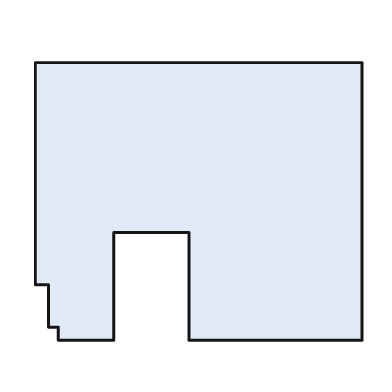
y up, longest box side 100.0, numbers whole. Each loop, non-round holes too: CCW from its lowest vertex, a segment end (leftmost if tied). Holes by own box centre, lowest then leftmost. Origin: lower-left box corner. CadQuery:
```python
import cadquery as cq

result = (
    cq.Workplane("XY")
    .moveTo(7.0, 0.0)
    .lineTo(24.0, 0.0)
    .lineTo(24.0, 33.0)
    .lineTo(47.0, 33.0)
    .lineTo(47.0, 0.0)
    .lineTo(100.0, 0.0)
    .lineTo(100.0, 85.0)
    .lineTo(0.0, 85.0)
    .lineTo(0.0, 17.0)
    .lineTo(4.0, 17.0)
    .lineTo(4.0, 4.0)
    .lineTo(7.0, 4.0)
    .close()
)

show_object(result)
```